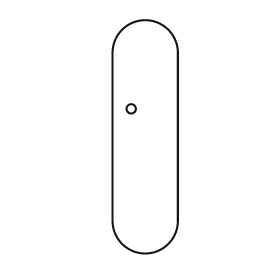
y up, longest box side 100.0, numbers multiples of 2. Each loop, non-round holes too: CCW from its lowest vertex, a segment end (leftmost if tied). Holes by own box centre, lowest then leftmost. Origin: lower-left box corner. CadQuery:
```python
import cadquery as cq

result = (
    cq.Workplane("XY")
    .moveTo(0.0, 14.0)
    .threePointArc((14.0, 0.0), (28.0, 14.0))
    .lineTo(28.0, 86.0)
    .threePointArc((14.0, 100.0), (0.0, 86.0))
    .close()
    .moveTo(8.0, 62.0)
    .circle(2.0)
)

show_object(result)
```